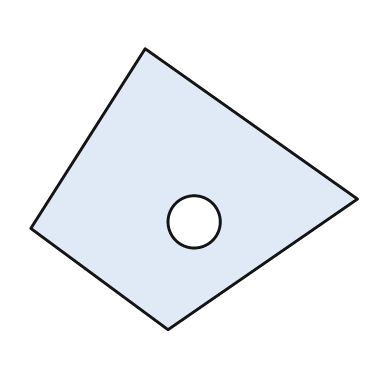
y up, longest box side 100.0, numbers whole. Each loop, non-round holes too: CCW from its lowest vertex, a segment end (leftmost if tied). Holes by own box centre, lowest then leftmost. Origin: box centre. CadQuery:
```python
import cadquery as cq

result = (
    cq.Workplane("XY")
    .moveTo(-8.0, -43.0)
    .lineTo(50.0, -3.0)
    .lineTo(-15.0, 43.0)
    .lineTo(-50.0, -12.0)
    .close()
    .moveTo(0.0, -10.0)
    .circle(8.0)
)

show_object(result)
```